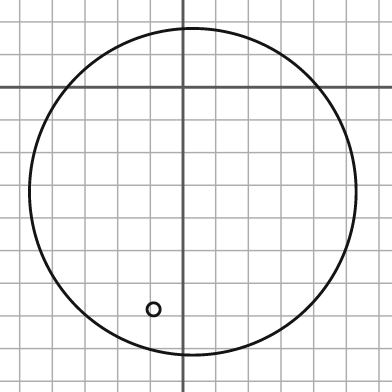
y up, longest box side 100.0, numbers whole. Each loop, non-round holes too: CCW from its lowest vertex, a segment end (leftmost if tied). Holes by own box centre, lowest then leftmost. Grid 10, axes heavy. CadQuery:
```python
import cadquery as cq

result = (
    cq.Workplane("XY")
    .moveTo(3.0, -32.0)
    .circle(50.0)
    .moveTo(-9.0, -68.0)
    .circle(2.0)
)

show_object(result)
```